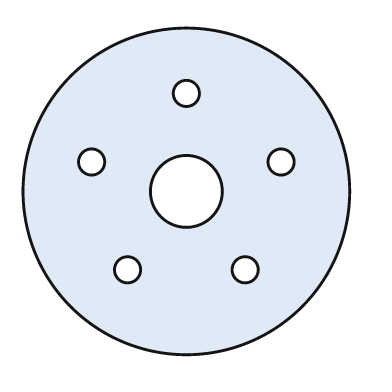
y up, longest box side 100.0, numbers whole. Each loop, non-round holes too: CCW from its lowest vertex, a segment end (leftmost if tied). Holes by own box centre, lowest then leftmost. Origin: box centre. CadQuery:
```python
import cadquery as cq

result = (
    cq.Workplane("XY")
    .moveTo(0.0, 0.0)
    .circle(50.0)
    .moveTo(-18.0, -24.0)
    .circle(4.0)
    .moveTo(18.0, -24.0)
    .circle(4.0)
    .moveTo(0.0, 0.0)
    .circle(11.0)
    .moveTo(-29.0, 9.0)
    .circle(4.0)
    .moveTo(29.0, 9.0)
    .circle(4.0)
    .moveTo(0.0, 30.0)
    .circle(4.0)
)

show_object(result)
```